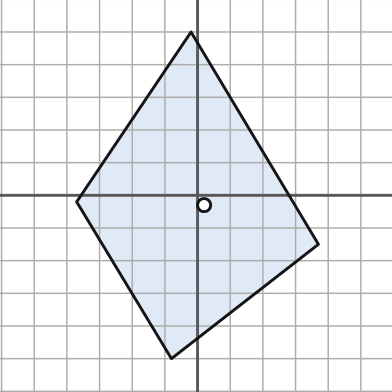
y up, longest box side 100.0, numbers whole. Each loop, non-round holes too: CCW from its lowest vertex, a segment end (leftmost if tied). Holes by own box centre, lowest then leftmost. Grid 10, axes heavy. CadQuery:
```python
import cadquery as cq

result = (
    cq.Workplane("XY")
    .moveTo(-8.0, -50.0)
    .lineTo(37.0, -15.0)
    .lineTo(-2.0, 50.0)
    .lineTo(-37.0, -2.0)
    .close()
    .moveTo(2.0, -3.0)
    .circle(2.0)
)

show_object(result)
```